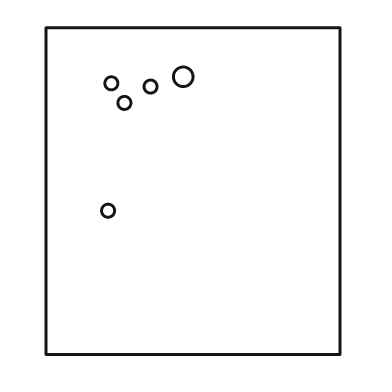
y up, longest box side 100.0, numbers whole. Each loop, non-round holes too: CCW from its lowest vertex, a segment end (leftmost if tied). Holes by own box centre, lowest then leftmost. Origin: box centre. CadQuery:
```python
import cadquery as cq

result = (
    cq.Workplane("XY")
    .moveTo(-45.0, -50.0)
    .lineTo(45.0, -50.0)
    .lineTo(45.0, 50.0)
    .lineTo(-45.0, 50.0)
    .close()
    .moveTo(-26.0, -6.0)
    .circle(2.0)
    .moveTo(-21.0, 27.0)
    .circle(2.0)
    .moveTo(-13.0, 32.0)
    .circle(2.0)
    .moveTo(-25.0, 33.0)
    .circle(2.0)
    .moveTo(-3.0, 35.0)
    .circle(3.0)
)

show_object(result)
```